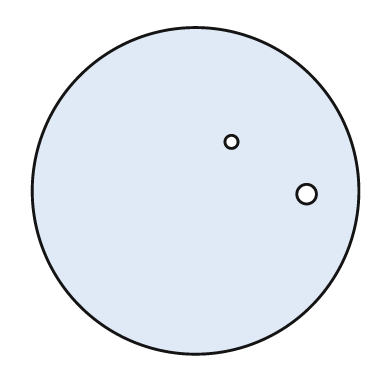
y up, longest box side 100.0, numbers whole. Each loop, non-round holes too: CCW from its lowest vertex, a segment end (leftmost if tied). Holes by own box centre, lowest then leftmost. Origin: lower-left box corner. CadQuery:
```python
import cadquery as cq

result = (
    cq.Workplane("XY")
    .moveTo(50.0, 50.0)
    .circle(50.0)
    .moveTo(84.0, 49.0)
    .circle(3.0)
    .moveTo(61.0, 65.0)
    .circle(2.0)
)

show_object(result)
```